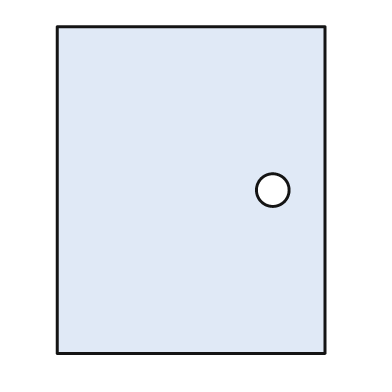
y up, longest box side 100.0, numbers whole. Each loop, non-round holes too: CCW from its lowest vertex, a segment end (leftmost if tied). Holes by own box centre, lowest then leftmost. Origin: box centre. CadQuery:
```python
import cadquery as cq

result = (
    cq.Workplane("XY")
    .moveTo(-41.0, -50.0)
    .lineTo(41.0, -50.0)
    .lineTo(41.0, 50.0)
    .lineTo(-41.0, 50.0)
    .close()
    .moveTo(25.0, 0.0)
    .circle(5.0)
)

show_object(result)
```